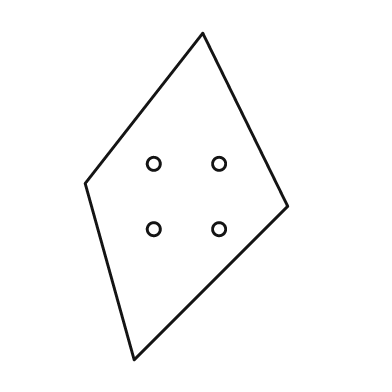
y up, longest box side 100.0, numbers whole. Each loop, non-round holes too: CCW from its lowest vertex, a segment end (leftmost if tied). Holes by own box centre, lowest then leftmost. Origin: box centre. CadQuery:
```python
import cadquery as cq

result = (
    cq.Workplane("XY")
    .moveTo(-16.0, -50.0)
    .lineTo(31.0, -3.0)
    .lineTo(5.0, 50.0)
    .lineTo(-31.0, 4.0)
    .close()
    .moveTo(-10.0, -10.0)
    .circle(2.0)
    .moveTo(10.0, -10.0)
    .circle(2.0)
    .moveTo(-10.0, 10.0)
    .circle(2.0)
    .moveTo(10.0, 10.0)
    .circle(2.0)
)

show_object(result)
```